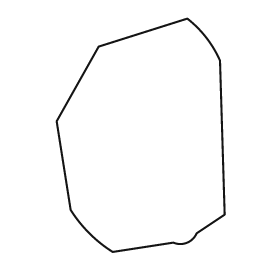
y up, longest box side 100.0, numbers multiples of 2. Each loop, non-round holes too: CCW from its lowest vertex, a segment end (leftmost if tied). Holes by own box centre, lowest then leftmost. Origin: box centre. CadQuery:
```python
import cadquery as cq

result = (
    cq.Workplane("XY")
    .moveTo(-12.0, -50.0)
    .lineTo(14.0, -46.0)
    .threePointArc((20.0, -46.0), (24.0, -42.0))
    .lineTo(36.0, -34.0)
    .lineTo(34.0, 32.0)
    .threePointArc((28.0, 42.0), (20.0, 50.0))
    .lineTo(-18.0, 38.0)
    .lineTo(-36.0, 6.0)
    .lineTo(-30.0, -32.0)
    .threePointArc((-22.0, -42.0), (-12.0, -50.0))
    .close()
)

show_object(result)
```